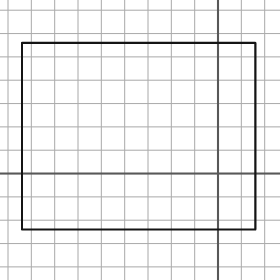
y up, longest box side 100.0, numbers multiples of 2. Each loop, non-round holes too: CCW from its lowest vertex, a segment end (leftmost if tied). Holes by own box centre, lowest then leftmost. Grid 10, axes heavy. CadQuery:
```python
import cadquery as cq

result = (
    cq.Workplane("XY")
    .moveTo(-84.0, -24.0)
    .lineTo(16.0, -24.0)
    .lineTo(16.0, 56.0)
    .lineTo(-84.0, 56.0)
    .close()
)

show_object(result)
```